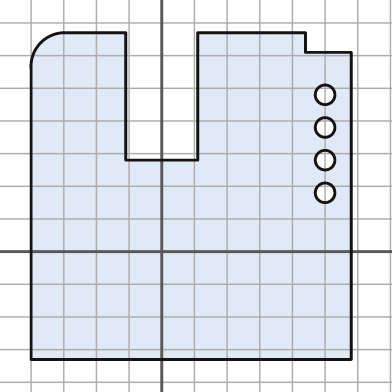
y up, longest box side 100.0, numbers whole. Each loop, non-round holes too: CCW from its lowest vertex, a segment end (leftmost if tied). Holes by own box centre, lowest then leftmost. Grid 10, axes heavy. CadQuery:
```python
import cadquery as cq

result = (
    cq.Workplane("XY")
    .moveTo(-40.0, -33.0)
    .lineTo(58.0, -33.0)
    .lineTo(58.0, 61.0)
    .lineTo(44.0, 61.0)
    .lineTo(44.0, 67.0)
    .lineTo(11.0, 67.0)
    .lineTo(11.0, 28.0)
    .lineTo(-11.0, 28.0)
    .lineTo(-11.0, 67.0)
    .lineTo(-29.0, 67.0)
    .threePointArc((-37.0, 64.0), (-40.0, 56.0))
    .close()
    .moveTo(50.0, 18.0)
    .circle(3.0)
    .moveTo(50.0, 28.0)
    .circle(3.0)
    .moveTo(50.0, 38.0)
    .circle(3.0)
    .moveTo(50.0, 48.0)
    .circle(3.0)
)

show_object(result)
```